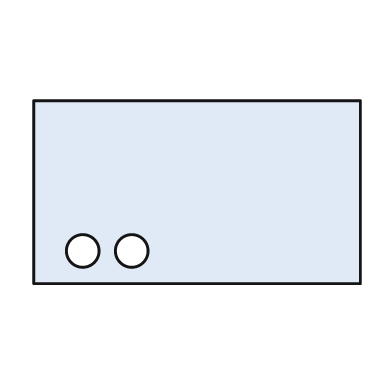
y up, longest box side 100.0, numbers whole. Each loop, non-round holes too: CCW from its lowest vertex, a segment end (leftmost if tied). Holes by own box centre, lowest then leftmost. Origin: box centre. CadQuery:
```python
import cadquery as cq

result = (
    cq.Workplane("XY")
    .moveTo(-50.0, -28.0)
    .lineTo(50.0, -28.0)
    .lineTo(50.0, 28.0)
    .lineTo(-50.0, 28.0)
    .close()
    .moveTo(-35.0, -18.0)
    .circle(5.0)
    .moveTo(-20.0, -18.0)
    .circle(5.0)
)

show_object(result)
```